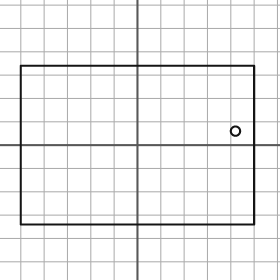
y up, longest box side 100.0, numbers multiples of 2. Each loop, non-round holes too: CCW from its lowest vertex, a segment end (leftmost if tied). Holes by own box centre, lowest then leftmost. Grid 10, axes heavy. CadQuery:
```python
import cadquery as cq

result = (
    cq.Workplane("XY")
    .moveTo(-50.0, -34.0)
    .lineTo(50.0, -34.0)
    .lineTo(50.0, 34.0)
    .lineTo(-50.0, 34.0)
    .close()
    .moveTo(42.0, 6.0)
    .circle(2.0)
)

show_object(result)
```